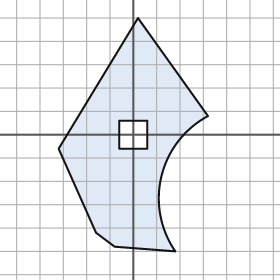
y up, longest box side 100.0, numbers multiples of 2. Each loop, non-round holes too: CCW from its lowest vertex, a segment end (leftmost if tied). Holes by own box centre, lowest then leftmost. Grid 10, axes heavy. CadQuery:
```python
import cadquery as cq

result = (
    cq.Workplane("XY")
    .moveTo(18.0, -50.0)
    .threePointArc((12.0, -18.0), (32.0, 8.0))
    .lineTo(2.0, 50.0)
    .lineTo(-32.0, -6.0)
    .lineTo(-16.0, -42.0)
    .lineTo(-8.0, -48.0)
    .close()
    .moveTo(-6.0, -6.0)
    .lineTo(6.0, -6.0)
    .lineTo(6.0, 6.0)
    .lineTo(-6.0, 6.0)
    .close()
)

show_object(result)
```